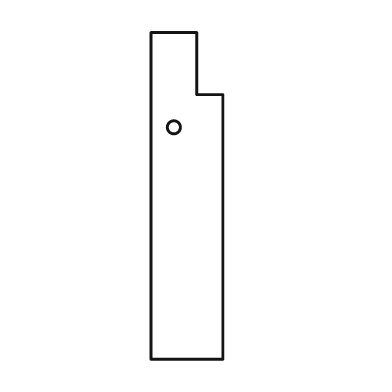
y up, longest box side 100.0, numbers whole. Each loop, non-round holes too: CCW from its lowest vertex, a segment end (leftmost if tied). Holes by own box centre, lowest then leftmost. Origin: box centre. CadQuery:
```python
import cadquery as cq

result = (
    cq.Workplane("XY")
    .moveTo(-11.0, -50.0)
    .lineTo(11.0, -50.0)
    .lineTo(11.0, 31.0)
    .lineTo(3.0, 31.0)
    .lineTo(3.0, 50.0)
    .lineTo(-11.0, 50.0)
    .close()
    .moveTo(-4.0, 21.0)
    .circle(2.0)
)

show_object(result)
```